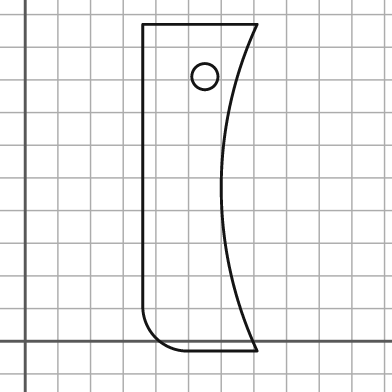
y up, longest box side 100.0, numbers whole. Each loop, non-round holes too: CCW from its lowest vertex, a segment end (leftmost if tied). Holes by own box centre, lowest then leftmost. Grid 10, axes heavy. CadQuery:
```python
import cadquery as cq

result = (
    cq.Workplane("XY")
    .moveTo(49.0, -3.0)
    .lineTo(71.0, -3.0)
    .threePointArc((60.0, 47.0), (71.0, 97.0))
    .lineTo(36.0, 97.0)
    .lineTo(36.0, 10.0)
    .threePointArc((40.0, 1.0), (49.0, -3.0))
    .close()
    .moveTo(55.0, 81.0)
    .circle(4.0)
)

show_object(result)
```